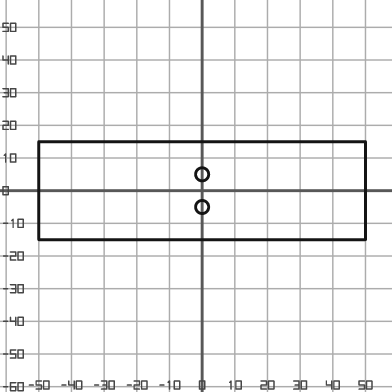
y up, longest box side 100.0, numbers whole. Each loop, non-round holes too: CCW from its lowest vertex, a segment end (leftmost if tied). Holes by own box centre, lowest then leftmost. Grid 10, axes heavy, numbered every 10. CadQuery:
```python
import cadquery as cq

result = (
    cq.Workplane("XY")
    .moveTo(-50.0, -15.0)
    .lineTo(50.0, -15.0)
    .lineTo(50.0, 15.0)
    .lineTo(-50.0, 15.0)
    .close()
    .moveTo(0.0, -5.0)
    .circle(2.0)
    .moveTo(0.0, 5.0)
    .circle(2.0)
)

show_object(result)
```